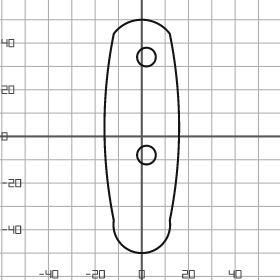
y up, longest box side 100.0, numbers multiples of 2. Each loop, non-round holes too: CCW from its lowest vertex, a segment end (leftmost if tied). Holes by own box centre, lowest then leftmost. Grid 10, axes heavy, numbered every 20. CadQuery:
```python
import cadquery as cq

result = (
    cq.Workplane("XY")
    .moveTo(-12.0, -36.0)
    .threePointArc((0.0, -50.0), (12.0, -36.0))
    .threePointArc((16.0, 4.0), (12.0, 44.0))
    .threePointArc((0.0, 50.0), (-12.0, 44.0))
    .threePointArc((-16.0, 4.0), (-12.0, -36.0))
    .close()
    .moveTo(2.0, -8.0)
    .circle(4.0)
    .moveTo(2.0, 34.0)
    .circle(4.0)
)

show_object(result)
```